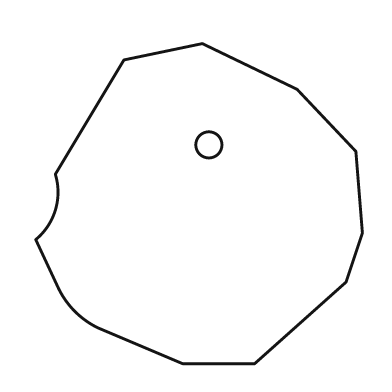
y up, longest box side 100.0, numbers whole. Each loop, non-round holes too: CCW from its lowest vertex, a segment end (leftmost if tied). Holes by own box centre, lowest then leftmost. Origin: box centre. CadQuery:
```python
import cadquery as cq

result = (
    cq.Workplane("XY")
    .moveTo(-5.0, -49.0)
    .lineTo(17.0, -49.0)
    .lineTo(45.0, -24.0)
    .lineTo(50.0, -9.0)
    .lineTo(48.0, 16.0)
    .lineTo(30.0, 35.0)
    .lineTo(1.0, 49.0)
    .lineTo(-23.0, 44.0)
    .lineTo(-44.0, 9.0)
    .threePointArc((-44.0, -2.0), (-50.0, -11.0))
    .lineTo(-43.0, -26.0)
    .threePointArc((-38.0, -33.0), (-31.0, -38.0))
    .close()
    .moveTo(3.0, 18.0)
    .circle(4.0)
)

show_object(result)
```